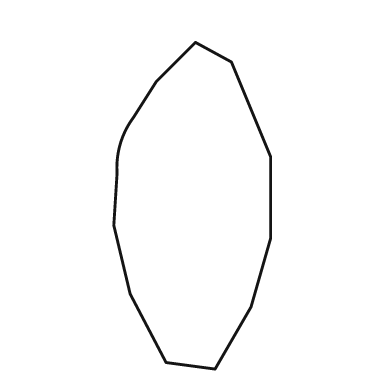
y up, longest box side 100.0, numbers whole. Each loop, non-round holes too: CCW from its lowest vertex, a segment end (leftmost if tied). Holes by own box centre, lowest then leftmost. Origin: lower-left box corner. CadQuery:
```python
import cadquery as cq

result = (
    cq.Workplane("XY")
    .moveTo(31.0, 0.0)
    .lineTo(42.0, 19.0)
    .lineTo(48.0, 40.0)
    .lineTo(48.0, 65.0)
    .lineTo(36.0, 94.0)
    .lineTo(25.0, 100.0)
    .lineTo(13.0, 88.0)
    .lineTo(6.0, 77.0)
    .threePointArc((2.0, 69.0), (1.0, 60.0))
    .lineTo(0.0, 44.0)
    .lineTo(5.0, 23.0)
    .lineTo(16.0, 2.0)
    .close()
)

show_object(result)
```